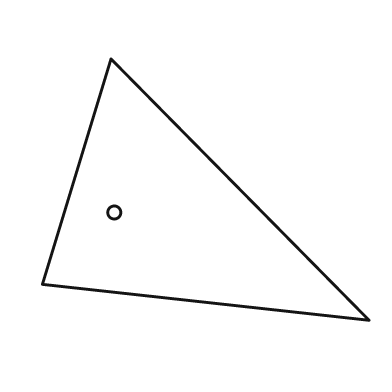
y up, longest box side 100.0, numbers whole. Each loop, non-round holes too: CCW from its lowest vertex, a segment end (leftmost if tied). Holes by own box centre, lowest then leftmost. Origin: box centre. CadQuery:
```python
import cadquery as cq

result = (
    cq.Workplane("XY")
    .moveTo(50.0, -40.0)
    .lineTo(-29.0, 40.0)
    .lineTo(-50.0, -29.0)
    .close()
    .moveTo(-28.0, -7.0)
    .circle(2.0)
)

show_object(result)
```